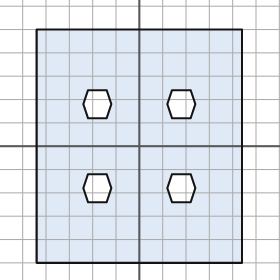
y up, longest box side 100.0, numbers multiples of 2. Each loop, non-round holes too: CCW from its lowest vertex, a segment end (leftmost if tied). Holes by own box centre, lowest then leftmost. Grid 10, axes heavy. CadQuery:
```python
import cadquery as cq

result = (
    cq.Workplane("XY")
    .moveTo(-44.0, -50.0)
    .lineTo(44.0, -50.0)
    .lineTo(44.0, 50.0)
    .lineTo(-44.0, 50.0)
    .close()
    .moveTo(-22.0, -24.0)
    .lineTo(-14.0, -24.0)
    .lineTo(-12.0, -18.0)
    .lineTo(-14.0, -12.0)
    .lineTo(-22.0, -12.0)
    .lineTo(-24.0, -18.0)
    .close()
    .moveTo(14.0, -24.0)
    .lineTo(22.0, -24.0)
    .lineTo(24.0, -18.0)
    .lineTo(22.0, -12.0)
    .lineTo(14.0, -12.0)
    .lineTo(12.0, -18.0)
    .close()
    .moveTo(-22.0, 12.0)
    .lineTo(-14.0, 12.0)
    .lineTo(-12.0, 18.0)
    .lineTo(-14.0, 24.0)
    .lineTo(-22.0, 24.0)
    .lineTo(-24.0, 18.0)
    .close()
    .moveTo(14.0, 12.0)
    .lineTo(22.0, 12.0)
    .lineTo(24.0, 18.0)
    .lineTo(22.0, 24.0)
    .lineTo(14.0, 24.0)
    .lineTo(12.0, 18.0)
    .close()
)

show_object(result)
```